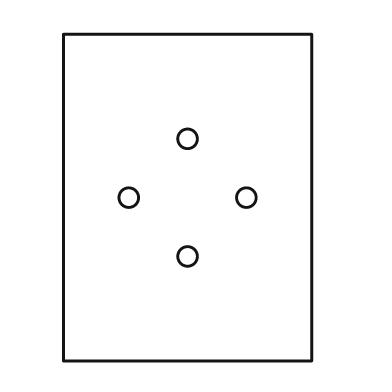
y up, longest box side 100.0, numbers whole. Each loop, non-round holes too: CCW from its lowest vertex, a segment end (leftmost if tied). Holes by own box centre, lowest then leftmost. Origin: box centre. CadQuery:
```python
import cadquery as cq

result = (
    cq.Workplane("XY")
    .moveTo(-38.0, -50.0)
    .lineTo(38.0, -50.0)
    .lineTo(38.0, 50.0)
    .lineTo(-38.0, 50.0)
    .close()
    .moveTo(0.0, -18.0)
    .circle(3.0)
    .moveTo(-18.0, 0.0)
    .circle(3.0)
    .moveTo(18.0, 0.0)
    .circle(3.0)
    .moveTo(0.0, 18.0)
    .circle(3.0)
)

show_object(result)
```